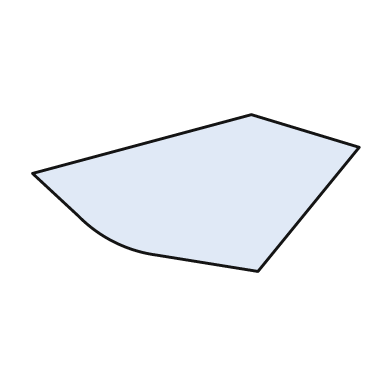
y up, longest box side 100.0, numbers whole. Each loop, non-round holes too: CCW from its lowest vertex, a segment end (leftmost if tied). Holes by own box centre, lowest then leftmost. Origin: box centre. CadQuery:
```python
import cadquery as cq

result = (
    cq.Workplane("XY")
    .moveTo(19.0, -24.0)
    .lineTo(50.0, 14.0)
    .lineTo(17.0, 24.0)
    .lineTo(-50.0, 6.0)
    .lineTo(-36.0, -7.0)
    .threePointArc((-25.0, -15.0), (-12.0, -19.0))
    .close()
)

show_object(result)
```